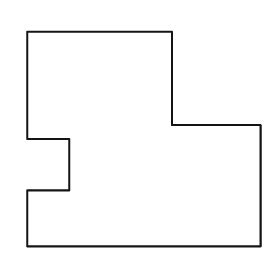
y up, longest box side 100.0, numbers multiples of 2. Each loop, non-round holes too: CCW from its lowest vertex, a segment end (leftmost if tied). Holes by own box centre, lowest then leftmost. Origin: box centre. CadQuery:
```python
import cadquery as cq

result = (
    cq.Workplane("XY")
    .moveTo(-50.0, -46.0)
    .lineTo(50.0, -46.0)
    .lineTo(50.0, 6.0)
    .lineTo(12.0, 6.0)
    .lineTo(12.0, 46.0)
    .lineTo(-50.0, 46.0)
    .lineTo(-50.0, 0.0)
    .lineTo(-32.0, 0.0)
    .lineTo(-32.0, -22.0)
    .lineTo(-50.0, -22.0)
    .close()
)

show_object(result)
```